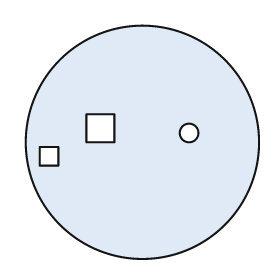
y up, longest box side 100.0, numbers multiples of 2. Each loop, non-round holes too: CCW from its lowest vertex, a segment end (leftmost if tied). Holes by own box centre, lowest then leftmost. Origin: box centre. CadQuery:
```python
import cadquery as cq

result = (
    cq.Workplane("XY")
    .moveTo(0.0, 0.0)
    .circle(50.0)
    .moveTo(-44.0, -10.0)
    .lineTo(-36.0, -10.0)
    .lineTo(-36.0, -2.0)
    .lineTo(-44.0, -2.0)
    .close()
    .moveTo(20.0, 4.0)
    .circle(4.0)
    .moveTo(-24.0, 0.0)
    .lineTo(-12.0, 0.0)
    .lineTo(-12.0, 12.0)
    .lineTo(-24.0, 12.0)
    .close()
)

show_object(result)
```